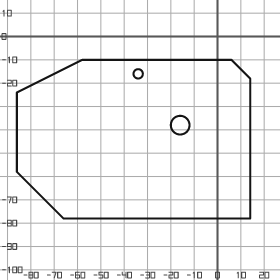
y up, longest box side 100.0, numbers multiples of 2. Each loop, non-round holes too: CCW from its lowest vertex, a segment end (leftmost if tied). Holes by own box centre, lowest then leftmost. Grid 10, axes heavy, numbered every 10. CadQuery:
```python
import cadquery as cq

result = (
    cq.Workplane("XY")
    .moveTo(-66.0, -78.0)
    .lineTo(14.0, -78.0)
    .lineTo(14.0, -18.0)
    .lineTo(6.0, -10.0)
    .lineTo(-58.0, -10.0)
    .lineTo(-86.0, -24.0)
    .lineTo(-86.0, -58.0)
    .close()
    .moveTo(-16.0, -38.0)
    .circle(4.0)
    .moveTo(-34.0, -16.0)
    .circle(2.0)
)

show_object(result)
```